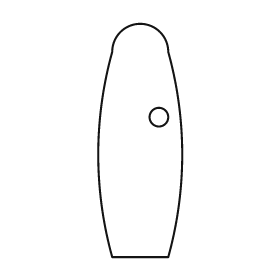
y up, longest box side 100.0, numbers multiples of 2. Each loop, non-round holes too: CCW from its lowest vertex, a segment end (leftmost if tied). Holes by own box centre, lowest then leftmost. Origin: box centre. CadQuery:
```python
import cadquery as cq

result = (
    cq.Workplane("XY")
    .moveTo(-12.0, -50.0)
    .lineTo(12.0, -50.0)
    .threePointArc((18.0, -6.0), (12.0, 38.0))
    .threePointArc((0.0, 50.0), (-12.0, 38.0))
    .threePointArc((-18.0, -6.0), (-12.0, -50.0))
    .close()
    .moveTo(8.0, 10.0)
    .circle(4.0)
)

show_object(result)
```